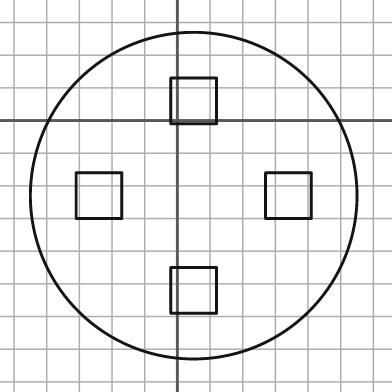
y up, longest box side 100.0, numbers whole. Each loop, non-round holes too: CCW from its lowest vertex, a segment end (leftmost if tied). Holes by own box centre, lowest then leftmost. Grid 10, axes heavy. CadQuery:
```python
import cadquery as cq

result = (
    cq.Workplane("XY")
    .moveTo(5.0, -23.0)
    .circle(50.0)
    .moveTo(-2.0, -59.0)
    .lineTo(12.0, -59.0)
    .lineTo(12.0, -45.0)
    .lineTo(-2.0, -45.0)
    .close()
    .moveTo(-31.0, -30.0)
    .lineTo(-17.0, -30.0)
    .lineTo(-17.0, -16.0)
    .lineTo(-31.0, -16.0)
    .close()
    .moveTo(27.0, -30.0)
    .lineTo(41.0, -30.0)
    .lineTo(41.0, -16.0)
    .lineTo(27.0, -16.0)
    .close()
    .moveTo(-2.0, -1.0)
    .lineTo(12.0, -1.0)
    .lineTo(12.0, 13.0)
    .lineTo(-2.0, 13.0)
    .close()
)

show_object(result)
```